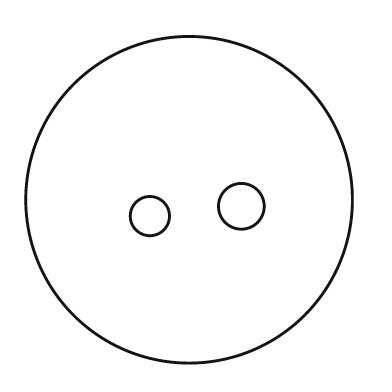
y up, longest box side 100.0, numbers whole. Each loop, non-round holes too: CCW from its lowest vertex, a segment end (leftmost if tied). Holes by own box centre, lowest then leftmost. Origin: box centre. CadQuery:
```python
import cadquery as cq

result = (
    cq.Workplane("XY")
    .moveTo(0.0, 0.0)
    .circle(50.0)
    .moveTo(-12.0, -5.0)
    .circle(6.0)
    .moveTo(16.0, -2.0)
    .circle(7.0)
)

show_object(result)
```